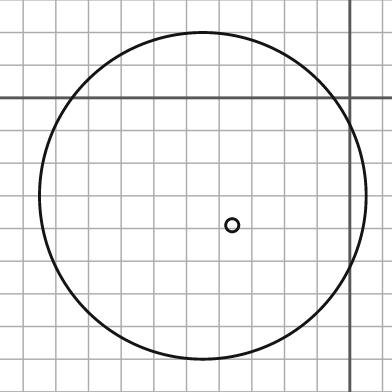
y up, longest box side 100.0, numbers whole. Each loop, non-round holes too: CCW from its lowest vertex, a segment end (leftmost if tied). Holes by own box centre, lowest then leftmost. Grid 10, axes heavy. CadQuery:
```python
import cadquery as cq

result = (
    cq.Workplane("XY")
    .moveTo(-45.0, -30.0)
    .circle(50.0)
    .moveTo(-36.0, -39.0)
    .circle(2.0)
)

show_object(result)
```